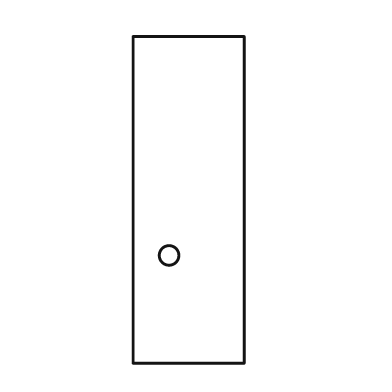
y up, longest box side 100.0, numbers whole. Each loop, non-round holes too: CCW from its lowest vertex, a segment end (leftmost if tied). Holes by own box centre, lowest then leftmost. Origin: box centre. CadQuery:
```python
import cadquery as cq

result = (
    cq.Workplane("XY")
    .moveTo(-17.0, -50.0)
    .lineTo(17.0, -50.0)
    .lineTo(17.0, 50.0)
    .lineTo(-17.0, 50.0)
    .close()
    .moveTo(-6.0, -17.0)
    .circle(3.0)
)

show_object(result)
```